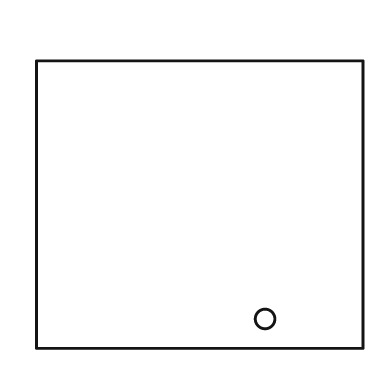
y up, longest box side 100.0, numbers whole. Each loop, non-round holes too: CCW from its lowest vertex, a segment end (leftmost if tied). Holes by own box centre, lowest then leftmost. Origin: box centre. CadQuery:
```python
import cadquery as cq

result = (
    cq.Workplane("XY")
    .moveTo(-50.0, -44.0)
    .lineTo(50.0, -44.0)
    .lineTo(50.0, 44.0)
    .lineTo(-50.0, 44.0)
    .close()
    .moveTo(20.0, -35.0)
    .circle(3.0)
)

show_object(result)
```